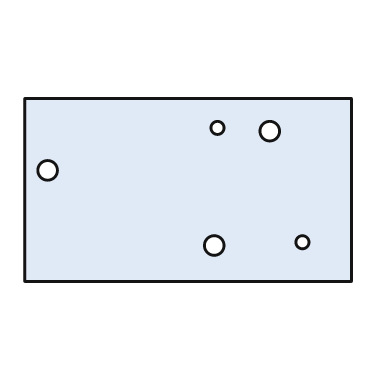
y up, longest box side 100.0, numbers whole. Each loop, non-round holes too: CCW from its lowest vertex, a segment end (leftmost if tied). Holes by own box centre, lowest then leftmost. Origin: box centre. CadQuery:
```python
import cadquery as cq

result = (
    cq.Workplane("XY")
    .moveTo(-50.0, -28.0)
    .lineTo(50.0, -28.0)
    .lineTo(50.0, 28.0)
    .lineTo(-50.0, 28.0)
    .close()
    .moveTo(8.0, -17.0)
    .circle(3.0)
    .moveTo(35.0, -16.0)
    .circle(2.0)
    .moveTo(-43.0, 6.0)
    .circle(3.0)
    .moveTo(25.0, 18.0)
    .circle(3.0)
    .moveTo(9.0, 19.0)
    .circle(2.0)
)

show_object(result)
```